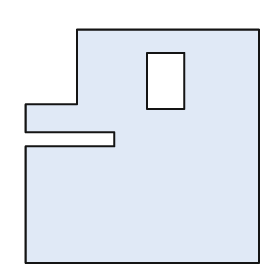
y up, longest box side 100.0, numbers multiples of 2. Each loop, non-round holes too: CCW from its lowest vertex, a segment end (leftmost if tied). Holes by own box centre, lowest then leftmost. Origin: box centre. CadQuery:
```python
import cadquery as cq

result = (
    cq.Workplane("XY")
    .moveTo(-50.0, -50.0)
    .lineTo(50.0, -50.0)
    .lineTo(50.0, 50.0)
    .lineTo(-28.0, 50.0)
    .lineTo(-28.0, 18.0)
    .lineTo(-50.0, 18.0)
    .lineTo(-50.0, 6.0)
    .lineTo(-12.0, 6.0)
    .lineTo(-12.0, 0.0)
    .lineTo(-50.0, 0.0)
    .close()
    .moveTo(2.0, 16.0)
    .lineTo(18.0, 16.0)
    .lineTo(18.0, 40.0)
    .lineTo(2.0, 40.0)
    .close()
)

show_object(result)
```